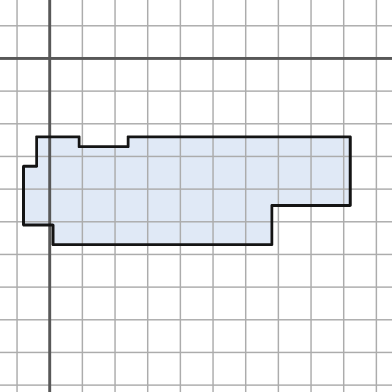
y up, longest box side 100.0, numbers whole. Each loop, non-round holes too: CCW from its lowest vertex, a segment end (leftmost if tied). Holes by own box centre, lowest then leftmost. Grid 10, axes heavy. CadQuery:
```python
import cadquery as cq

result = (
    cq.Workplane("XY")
    .moveTo(1.0, -57.0)
    .lineTo(68.0, -57.0)
    .lineTo(68.0, -45.0)
    .lineTo(92.0, -45.0)
    .lineTo(92.0, -24.0)
    .lineTo(24.0, -24.0)
    .lineTo(24.0, -27.0)
    .lineTo(9.0, -27.0)
    .lineTo(9.0, -24.0)
    .lineTo(-4.0, -24.0)
    .lineTo(-4.0, -33.0)
    .lineTo(-8.0, -33.0)
    .lineTo(-8.0, -51.0)
    .lineTo(1.0, -51.0)
    .close()
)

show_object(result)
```